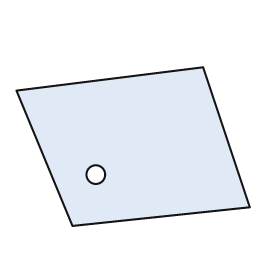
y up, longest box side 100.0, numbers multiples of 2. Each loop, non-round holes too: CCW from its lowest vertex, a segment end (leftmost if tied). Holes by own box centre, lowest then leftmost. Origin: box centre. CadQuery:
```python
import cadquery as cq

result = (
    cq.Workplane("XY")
    .moveTo(-26.0, -34.0)
    .lineTo(50.0, -26.0)
    .lineTo(30.0, 34.0)
    .lineTo(-50.0, 24.0)
    .close()
    .moveTo(-16.0, -12.0)
    .circle(4.0)
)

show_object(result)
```